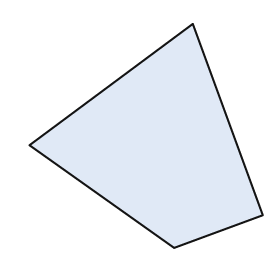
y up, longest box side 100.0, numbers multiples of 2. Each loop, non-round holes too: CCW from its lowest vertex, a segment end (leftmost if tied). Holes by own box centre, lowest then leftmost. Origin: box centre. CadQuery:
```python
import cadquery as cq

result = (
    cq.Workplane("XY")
    .moveTo(12.0, -48.0)
    .lineTo(50.0, -34.0)
    .lineTo(20.0, 48.0)
    .lineTo(-50.0, -4.0)
    .close()
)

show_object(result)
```